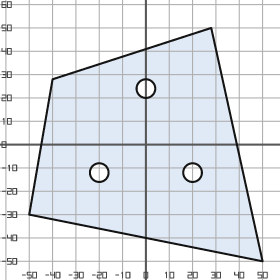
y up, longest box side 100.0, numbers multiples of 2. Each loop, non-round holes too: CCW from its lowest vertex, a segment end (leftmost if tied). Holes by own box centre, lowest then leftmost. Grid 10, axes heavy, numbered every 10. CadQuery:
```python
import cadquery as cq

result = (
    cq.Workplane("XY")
    .moveTo(50.0, -50.0)
    .lineTo(28.0, 50.0)
    .lineTo(-40.0, 28.0)
    .lineTo(-50.0, -30.0)
    .close()
    .moveTo(-20.0, -12.0)
    .circle(4.0)
    .moveTo(20.0, -12.0)
    .circle(4.0)
    .moveTo(0.0, 24.0)
    .circle(4.0)
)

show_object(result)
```